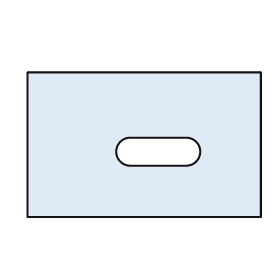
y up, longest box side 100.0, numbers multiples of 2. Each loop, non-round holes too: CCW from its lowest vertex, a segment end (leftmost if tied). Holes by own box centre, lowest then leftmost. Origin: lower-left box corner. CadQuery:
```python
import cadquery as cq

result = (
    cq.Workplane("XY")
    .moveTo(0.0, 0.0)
    .lineTo(100.0, 0.0)
    .lineTo(100.0, 62.0)
    .lineTo(0.0, 62.0)
    .close()
    .moveTo(44.0, 22.0)
    .lineTo(68.0, 22.0)
    .threePointArc((74.0, 28.0), (68.0, 34.0))
    .lineTo(44.0, 34.0)
    .threePointArc((38.0, 28.0), (44.0, 22.0))
    .close()
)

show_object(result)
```